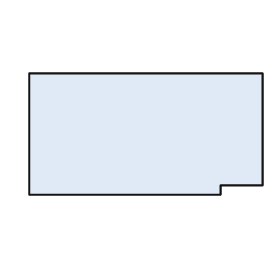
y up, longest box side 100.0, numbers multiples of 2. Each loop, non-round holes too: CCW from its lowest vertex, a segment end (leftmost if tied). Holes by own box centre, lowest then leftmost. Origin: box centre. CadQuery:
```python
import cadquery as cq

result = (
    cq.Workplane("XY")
    .moveTo(-50.0, -26.0)
    .lineTo(32.0, -26.0)
    .lineTo(32.0, -22.0)
    .lineTo(50.0, -22.0)
    .lineTo(50.0, 26.0)
    .lineTo(-50.0, 26.0)
    .close()
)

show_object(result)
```